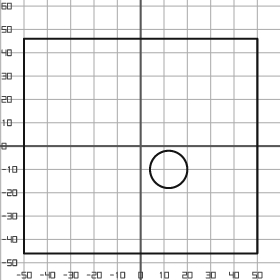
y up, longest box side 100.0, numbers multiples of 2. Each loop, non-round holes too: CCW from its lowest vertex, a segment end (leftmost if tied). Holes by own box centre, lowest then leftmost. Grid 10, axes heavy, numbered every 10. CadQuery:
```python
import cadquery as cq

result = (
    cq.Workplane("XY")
    .moveTo(-50.0, -46.0)
    .lineTo(50.0, -46.0)
    .lineTo(50.0, 46.0)
    .lineTo(-50.0, 46.0)
    .close()
    .moveTo(12.0, -10.0)
    .circle(8.0)
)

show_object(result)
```